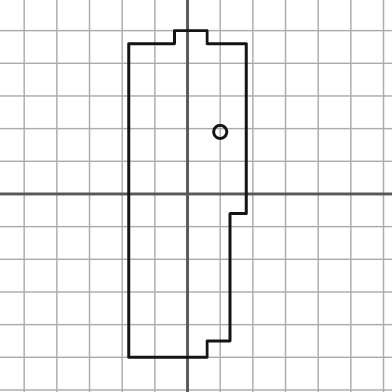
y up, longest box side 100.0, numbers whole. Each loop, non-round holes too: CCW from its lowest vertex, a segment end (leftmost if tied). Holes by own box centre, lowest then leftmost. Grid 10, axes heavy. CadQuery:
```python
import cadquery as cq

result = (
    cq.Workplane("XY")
    .moveTo(-18.0, -50.0)
    .lineTo(6.0, -50.0)
    .lineTo(6.0, -45.0)
    .lineTo(13.0, -45.0)
    .lineTo(13.0, -6.0)
    .lineTo(18.0, -6.0)
    .lineTo(18.0, 46.0)
    .lineTo(6.0, 46.0)
    .lineTo(6.0, 50.0)
    .lineTo(-4.0, 50.0)
    .lineTo(-4.0, 46.0)
    .lineTo(-18.0, 46.0)
    .close()
    .moveTo(10.0, 19.0)
    .circle(2.0)
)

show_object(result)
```